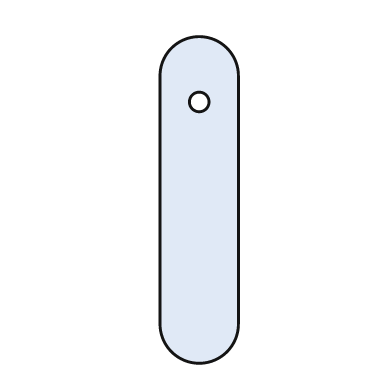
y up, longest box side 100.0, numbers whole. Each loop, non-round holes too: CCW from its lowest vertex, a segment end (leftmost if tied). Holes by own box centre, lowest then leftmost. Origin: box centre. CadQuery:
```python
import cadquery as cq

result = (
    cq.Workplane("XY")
    .moveTo(-12.0, -38.0)
    .threePointArc((0.0, -50.0), (12.0, -38.0))
    .lineTo(12.0, 38.0)
    .threePointArc((0.0, 50.0), (-12.0, 38.0))
    .close()
    .moveTo(0.0, 30.0)
    .circle(3.0)
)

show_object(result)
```